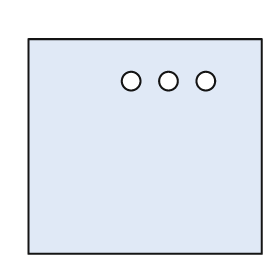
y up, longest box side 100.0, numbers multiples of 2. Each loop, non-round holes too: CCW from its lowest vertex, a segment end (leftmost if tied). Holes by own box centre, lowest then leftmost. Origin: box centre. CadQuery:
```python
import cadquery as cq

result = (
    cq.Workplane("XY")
    .moveTo(-50.0, -46.0)
    .lineTo(50.0, -46.0)
    .lineTo(50.0, 46.0)
    .lineTo(-50.0, 46.0)
    .close()
    .moveTo(-6.0, 28.0)
    .circle(4.0)
    .moveTo(10.0, 28.0)
    .circle(4.0)
    .moveTo(26.0, 28.0)
    .circle(4.0)
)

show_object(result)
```